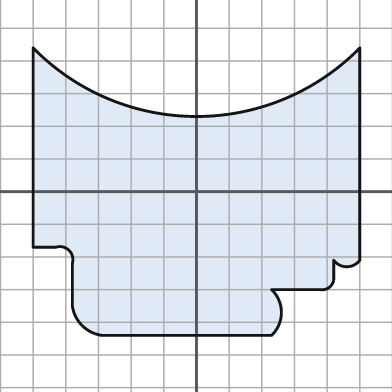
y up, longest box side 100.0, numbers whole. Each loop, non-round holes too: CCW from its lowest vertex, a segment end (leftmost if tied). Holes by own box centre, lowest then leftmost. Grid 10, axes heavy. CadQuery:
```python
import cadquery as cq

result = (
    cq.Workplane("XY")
    .moveTo(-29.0, -44.0)
    .lineTo(23.0, -44.0)
    .threePointArc((26.0, -37.0), (23.0, -30.0))
    .lineTo(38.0, -30.0)
    .threePointArc((41.0, -29.0), (42.0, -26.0))
    .lineTo(42.0, -21.0)
    .threePointArc((46.0, -23.0), (50.0, -21.0))
    .lineTo(50.0, 44.0)
    .threePointArc((0.0, 23.0), (-50.0, 44.0))
    .lineTo(-50.0, -17.0)
    .lineTo(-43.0, -17.0)
    .threePointArc((-39.0, -18.0), (-38.0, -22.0))
    .lineTo(-38.0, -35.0)
    .threePointArc((-35.0, -41.0), (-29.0, -44.0))
    .close()
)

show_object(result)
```